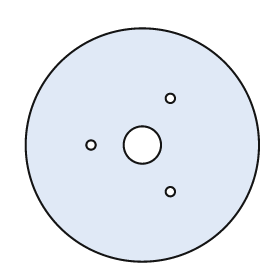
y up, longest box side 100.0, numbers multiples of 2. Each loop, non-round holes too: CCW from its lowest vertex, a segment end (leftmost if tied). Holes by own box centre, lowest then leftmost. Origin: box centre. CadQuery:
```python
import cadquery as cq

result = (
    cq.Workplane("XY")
    .moveTo(0.0, 0.0)
    .circle(50.0)
    .moveTo(12.0, -20.0)
    .circle(2.0)
    .moveTo(-22.0, 0.0)
    .circle(2.0)
    .moveTo(0.0, 0.0)
    .circle(8.0)
    .moveTo(12.0, 20.0)
    .circle(2.0)
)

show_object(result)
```